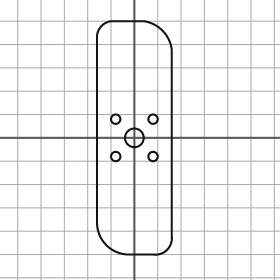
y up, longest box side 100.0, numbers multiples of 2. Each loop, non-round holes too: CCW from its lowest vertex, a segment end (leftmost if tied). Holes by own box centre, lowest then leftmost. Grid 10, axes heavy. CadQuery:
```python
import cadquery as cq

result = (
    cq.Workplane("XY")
    .moveTo(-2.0, -50.0)
    .lineTo(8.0, -50.0)
    .threePointArc((14.0, -48.0), (16.0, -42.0))
    .lineTo(16.0, 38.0)
    .threePointArc((12.0, 46.0), (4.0, 50.0))
    .lineTo(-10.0, 50.0)
    .threePointArc((-14.0, 48.0), (-16.0, 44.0))
    .lineTo(-16.0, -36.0)
    .threePointArc((-12.0, -46.0), (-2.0, -50.0))
    .close()
    .moveTo(-8.0, -8.0)
    .circle(2.0)
    .moveTo(8.0, -8.0)
    .circle(2.0)
    .moveTo(0.0, 0.0)
    .circle(4.0)
    .moveTo(-8.0, 8.0)
    .circle(2.0)
    .moveTo(8.0, 8.0)
    .circle(2.0)
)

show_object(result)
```